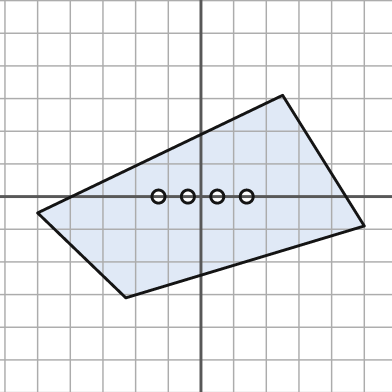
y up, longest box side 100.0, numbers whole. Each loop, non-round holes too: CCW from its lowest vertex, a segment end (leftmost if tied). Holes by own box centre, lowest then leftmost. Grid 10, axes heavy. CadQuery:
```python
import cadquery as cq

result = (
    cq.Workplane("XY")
    .moveTo(-23.0, -31.0)
    .lineTo(50.0, -9.0)
    .lineTo(25.0, 31.0)
    .lineTo(-50.0, -5.0)
    .close()
    .moveTo(-13.0, 0.0)
    .circle(2.0)
    .moveTo(-4.0, 0.0)
    .circle(2.0)
    .moveTo(5.0, 0.0)
    .circle(2.0)
    .moveTo(14.0, 0.0)
    .circle(2.0)
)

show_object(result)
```